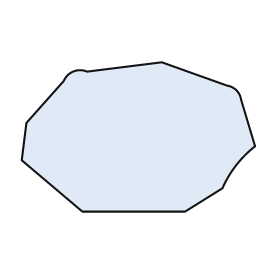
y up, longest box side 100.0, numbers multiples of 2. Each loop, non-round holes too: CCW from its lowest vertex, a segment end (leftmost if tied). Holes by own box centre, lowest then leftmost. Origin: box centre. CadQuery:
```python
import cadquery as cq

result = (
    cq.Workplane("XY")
    .moveTo(-24.0, -32.0)
    .lineTo(20.0, -32.0)
    .lineTo(36.0, -22.0)
    .threePointArc((42.0, -12.0), (50.0, -4.0))
    .lineTo(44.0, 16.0)
    .threePointArc((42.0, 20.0), (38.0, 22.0))
    .lineTo(10.0, 32.0)
    .lineTo(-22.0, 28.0)
    .threePointArc((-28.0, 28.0), (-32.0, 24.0))
    .lineTo(-48.0, 6.0)
    .lineTo(-50.0, -10.0)
    .close()
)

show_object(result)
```